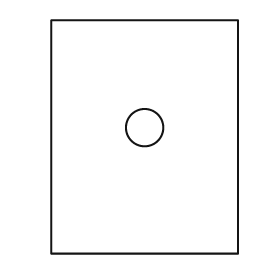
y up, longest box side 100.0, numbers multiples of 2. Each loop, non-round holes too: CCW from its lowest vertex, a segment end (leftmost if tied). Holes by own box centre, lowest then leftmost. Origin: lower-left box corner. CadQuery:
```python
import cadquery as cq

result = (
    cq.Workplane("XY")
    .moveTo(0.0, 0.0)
    .lineTo(80.0, 0.0)
    .lineTo(80.0, 100.0)
    .lineTo(0.0, 100.0)
    .close()
    .moveTo(40.0, 54.0)
    .circle(8.0)
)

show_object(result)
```